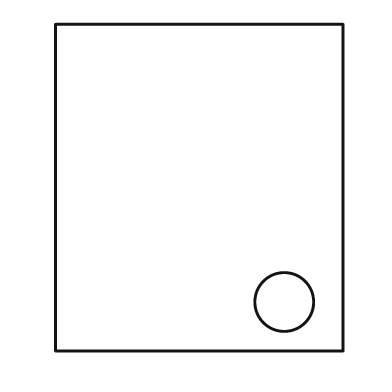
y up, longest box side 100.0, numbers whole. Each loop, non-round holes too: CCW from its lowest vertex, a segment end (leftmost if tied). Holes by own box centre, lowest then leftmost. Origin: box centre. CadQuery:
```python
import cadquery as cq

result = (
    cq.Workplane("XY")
    .moveTo(-44.0, -50.0)
    .lineTo(44.0, -50.0)
    .lineTo(44.0, 50.0)
    .lineTo(-44.0, 50.0)
    .close()
    .moveTo(26.0, -35.0)
    .circle(9.0)
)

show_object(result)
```